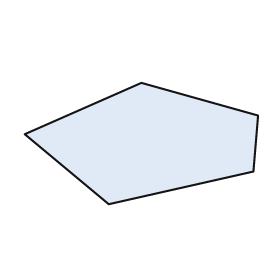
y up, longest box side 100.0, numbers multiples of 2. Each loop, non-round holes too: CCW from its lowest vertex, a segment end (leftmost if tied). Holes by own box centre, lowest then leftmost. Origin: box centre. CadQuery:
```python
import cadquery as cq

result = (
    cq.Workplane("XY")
    .moveTo(-14.0, -26.0)
    .lineTo(48.0, -12.0)
    .lineTo(50.0, 12.0)
    .lineTo(0.0, 26.0)
    .lineTo(-50.0, 4.0)
    .close()
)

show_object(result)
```